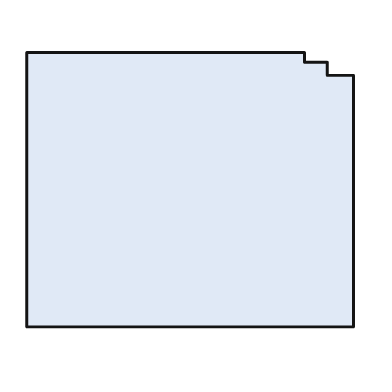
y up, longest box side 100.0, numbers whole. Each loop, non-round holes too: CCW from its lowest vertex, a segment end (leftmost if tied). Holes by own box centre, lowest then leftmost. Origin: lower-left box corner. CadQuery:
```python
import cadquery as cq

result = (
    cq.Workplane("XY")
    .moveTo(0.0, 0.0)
    .lineTo(100.0, 0.0)
    .lineTo(100.0, 77.0)
    .lineTo(92.0, 77.0)
    .lineTo(92.0, 81.0)
    .lineTo(85.0, 81.0)
    .lineTo(85.0, 84.0)
    .lineTo(0.0, 84.0)
    .close()
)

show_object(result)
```